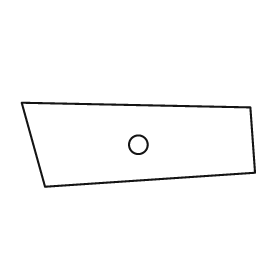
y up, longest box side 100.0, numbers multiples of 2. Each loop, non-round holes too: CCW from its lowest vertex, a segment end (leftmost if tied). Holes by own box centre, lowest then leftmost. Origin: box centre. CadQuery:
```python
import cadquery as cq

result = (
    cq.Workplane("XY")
    .moveTo(-40.0, -18.0)
    .lineTo(50.0, -12.0)
    .lineTo(48.0, 16.0)
    .lineTo(-50.0, 18.0)
    .close()
    .moveTo(0.0, 0.0)
    .circle(4.0)
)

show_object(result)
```